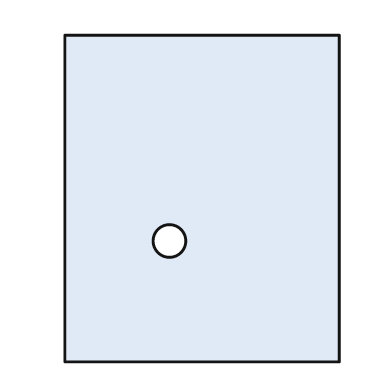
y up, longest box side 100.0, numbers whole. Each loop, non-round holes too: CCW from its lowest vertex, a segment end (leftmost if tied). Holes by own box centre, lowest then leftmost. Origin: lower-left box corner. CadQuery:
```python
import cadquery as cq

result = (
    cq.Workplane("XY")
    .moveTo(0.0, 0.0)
    .lineTo(84.0, 0.0)
    .lineTo(84.0, 100.0)
    .lineTo(0.0, 100.0)
    .close()
    .moveTo(32.0, 37.0)
    .circle(5.0)
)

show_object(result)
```